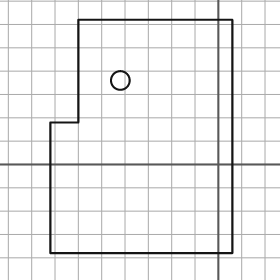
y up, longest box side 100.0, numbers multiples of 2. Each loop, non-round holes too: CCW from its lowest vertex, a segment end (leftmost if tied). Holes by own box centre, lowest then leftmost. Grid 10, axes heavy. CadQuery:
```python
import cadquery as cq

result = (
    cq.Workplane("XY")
    .moveTo(-72.0, -38.0)
    .lineTo(6.0, -38.0)
    .lineTo(6.0, 62.0)
    .lineTo(-60.0, 62.0)
    .lineTo(-60.0, 18.0)
    .lineTo(-72.0, 18.0)
    .close()
    .moveTo(-42.0, 36.0)
    .circle(4.0)
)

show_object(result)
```